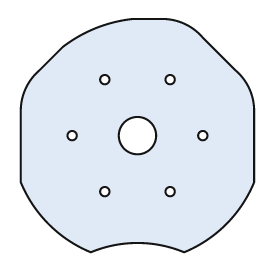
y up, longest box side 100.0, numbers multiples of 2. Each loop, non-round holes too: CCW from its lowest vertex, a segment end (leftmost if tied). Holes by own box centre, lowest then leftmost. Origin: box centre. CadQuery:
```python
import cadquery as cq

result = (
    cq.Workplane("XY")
    .moveTo(-20.0, -50.0)
    .threePointArc((0.0, -46.0), (20.0, -50.0))
    .threePointArc((38.0, -38.0), (50.0, -20.0))
    .lineTo(50.0, 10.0)
    .threePointArc((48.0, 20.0), (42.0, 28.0))
    .lineTo(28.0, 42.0)
    .threePointArc((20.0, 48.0), (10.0, 50.0))
    .lineTo(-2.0, 50.0)
    .threePointArc((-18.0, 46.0), (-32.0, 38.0))
    .lineTo(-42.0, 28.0)
    .threePointArc((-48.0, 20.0), (-50.0, 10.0))
    .lineTo(-50.0, -20.0)
    .threePointArc((-38.0, -38.0), (-20.0, -50.0))
    .close()
    .moveTo(-14.0, -24.0)
    .circle(2.0)
    .moveTo(14.0, -24.0)
    .circle(2.0)
    .moveTo(-28.0, 0.0)
    .circle(2.0)
    .moveTo(0.0, 0.0)
    .circle(8.0)
    .moveTo(28.0, 0.0)
    .circle(2.0)
    .moveTo(-14.0, 24.0)
    .circle(2.0)
    .moveTo(14.0, 24.0)
    .circle(2.0)
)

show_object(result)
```